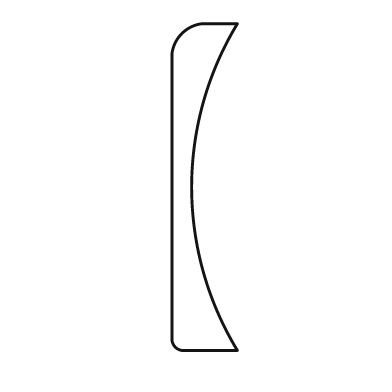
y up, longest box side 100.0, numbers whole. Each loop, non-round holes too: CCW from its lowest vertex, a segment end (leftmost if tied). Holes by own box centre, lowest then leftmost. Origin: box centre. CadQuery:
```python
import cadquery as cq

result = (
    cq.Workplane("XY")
    .moveTo(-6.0, -50.0)
    .lineTo(10.0, -50.0)
    .threePointArc((-4.0, 0.0), (10.0, 50.0))
    .lineTo(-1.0, 50.0)
    .threePointArc((-7.0, 47.0), (-10.0, 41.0))
    .lineTo(-10.0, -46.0)
    .threePointArc((-9.0, -49.0), (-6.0, -50.0))
    .close()
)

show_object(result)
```